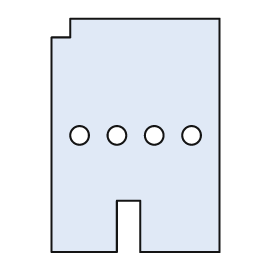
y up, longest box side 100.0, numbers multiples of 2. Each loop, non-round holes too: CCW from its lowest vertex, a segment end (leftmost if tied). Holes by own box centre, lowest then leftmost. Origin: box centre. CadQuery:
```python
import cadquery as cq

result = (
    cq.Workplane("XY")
    .moveTo(-36.0, -50.0)
    .lineTo(-8.0, -50.0)
    .lineTo(-8.0, -28.0)
    .lineTo(2.0, -28.0)
    .lineTo(2.0, -50.0)
    .lineTo(36.0, -50.0)
    .lineTo(36.0, 50.0)
    .lineTo(-28.0, 50.0)
    .lineTo(-28.0, 42.0)
    .lineTo(-36.0, 42.0)
    .close()
    .moveTo(-24.0, 0.0)
    .circle(4.0)
    .moveTo(-8.0, 0.0)
    .circle(4.0)
    .moveTo(8.0, 0.0)
    .circle(4.0)
    .moveTo(24.0, 0.0)
    .circle(4.0)
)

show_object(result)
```